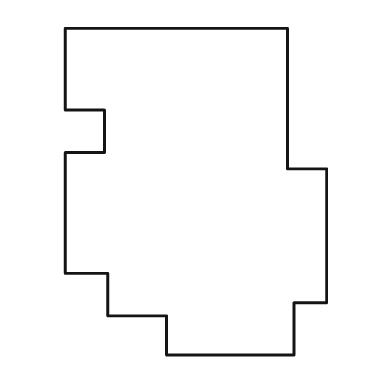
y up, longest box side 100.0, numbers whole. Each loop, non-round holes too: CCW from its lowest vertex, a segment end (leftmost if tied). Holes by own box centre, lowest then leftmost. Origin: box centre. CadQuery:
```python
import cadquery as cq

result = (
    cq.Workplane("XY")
    .moveTo(-9.0, -50.0)
    .lineTo(30.0, -50.0)
    .lineTo(30.0, -34.0)
    .lineTo(40.0, -34.0)
    .lineTo(40.0, 7.0)
    .lineTo(28.0, 7.0)
    .lineTo(28.0, 50.0)
    .lineTo(-40.0, 50.0)
    .lineTo(-40.0, 25.0)
    .lineTo(-28.0, 25.0)
    .lineTo(-28.0, 12.0)
    .lineTo(-40.0, 12.0)
    .lineTo(-40.0, -25.0)
    .lineTo(-27.0, -25.0)
    .lineTo(-27.0, -38.0)
    .lineTo(-9.0, -38.0)
    .close()
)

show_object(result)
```